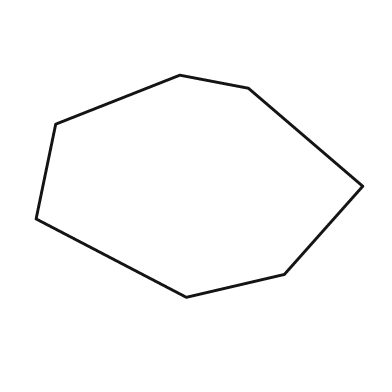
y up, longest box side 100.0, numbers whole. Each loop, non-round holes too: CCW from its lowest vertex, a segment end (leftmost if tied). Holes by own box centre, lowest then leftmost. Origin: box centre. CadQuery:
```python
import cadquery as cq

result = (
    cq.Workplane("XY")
    .moveTo(-4.0, -34.0)
    .lineTo(26.0, -27.0)
    .lineTo(50.0, 0.0)
    .lineTo(15.0, 30.0)
    .lineTo(-6.0, 34.0)
    .lineTo(-44.0, 19.0)
    .lineTo(-50.0, -10.0)
    .close()
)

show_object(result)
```